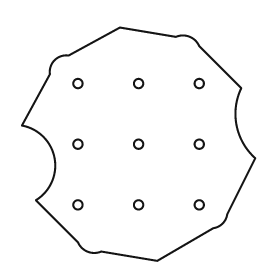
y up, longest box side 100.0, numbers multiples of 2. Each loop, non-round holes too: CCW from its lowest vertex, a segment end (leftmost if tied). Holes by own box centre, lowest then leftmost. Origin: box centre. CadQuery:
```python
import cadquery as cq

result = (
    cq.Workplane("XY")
    .moveTo(8.0, -50.0)
    .lineTo(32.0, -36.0)
    .threePointArc((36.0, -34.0), (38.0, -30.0))
    .lineTo(50.0, -6.0)
    .threePointArc((42.0, 8.0), (44.0, 24.0))
    .lineTo(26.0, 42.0)
    .threePointArc((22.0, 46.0), (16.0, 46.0))
    .lineTo(-8.0, 50.0)
    .lineTo(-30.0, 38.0)
    .threePointArc((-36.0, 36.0), (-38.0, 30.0))
    .lineTo(-50.0, 8.0)
    .threePointArc((-36.0, -6.0), (-44.0, -24.0))
    .lineTo(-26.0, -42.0)
    .threePointArc((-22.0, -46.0), (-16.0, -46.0))
    .close()
    .moveTo(-26.0, -26.0)
    .circle(2.0)
    .moveTo(0.0, -26.0)
    .circle(2.0)
    .moveTo(26.0, -26.0)
    .circle(2.0)
    .moveTo(-26.0, 0.0)
    .circle(2.0)
    .moveTo(0.0, 0.0)
    .circle(2.0)
    .moveTo(26.0, 0.0)
    .circle(2.0)
    .moveTo(-26.0, 26.0)
    .circle(2.0)
    .moveTo(0.0, 26.0)
    .circle(2.0)
    .moveTo(26.0, 26.0)
    .circle(2.0)
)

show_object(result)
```